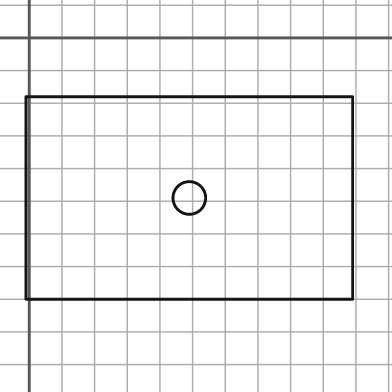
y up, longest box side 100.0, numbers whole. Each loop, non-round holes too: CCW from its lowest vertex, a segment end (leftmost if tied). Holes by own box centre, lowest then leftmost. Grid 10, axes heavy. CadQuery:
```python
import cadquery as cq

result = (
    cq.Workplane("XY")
    .moveTo(-1.0, -80.0)
    .lineTo(99.0, -80.0)
    .lineTo(99.0, -18.0)
    .lineTo(-1.0, -18.0)
    .close()
    .moveTo(49.0, -49.0)
    .circle(5.0)
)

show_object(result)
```